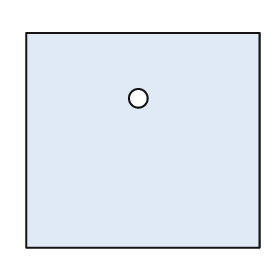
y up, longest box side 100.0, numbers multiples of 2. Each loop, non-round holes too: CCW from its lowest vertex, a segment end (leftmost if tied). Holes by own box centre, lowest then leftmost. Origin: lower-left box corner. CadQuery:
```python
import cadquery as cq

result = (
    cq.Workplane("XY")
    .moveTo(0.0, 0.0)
    .lineTo(100.0, 0.0)
    .lineTo(100.0, 92.0)
    .lineTo(0.0, 92.0)
    .close()
    .moveTo(48.0, 64.0)
    .circle(4.0)
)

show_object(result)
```